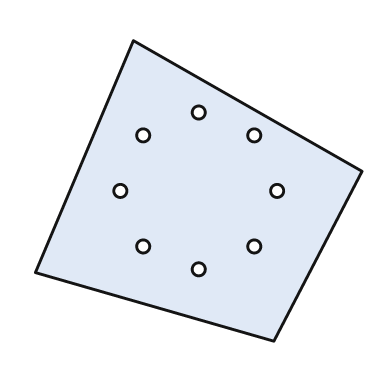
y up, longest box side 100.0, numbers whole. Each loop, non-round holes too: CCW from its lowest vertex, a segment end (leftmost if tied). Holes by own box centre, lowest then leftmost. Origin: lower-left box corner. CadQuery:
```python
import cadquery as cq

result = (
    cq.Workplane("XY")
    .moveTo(73.0, 0.0)
    .lineTo(100.0, 52.0)
    .lineTo(30.0, 92.0)
    .lineTo(0.0, 21.0)
    .close()
    .moveTo(50.0, 22.0)
    .circle(2.0)
    .moveTo(33.0, 29.0)
    .circle(2.0)
    .moveTo(67.0, 29.0)
    .circle(2.0)
    .moveTo(26.0, 46.0)
    .circle(2.0)
    .moveTo(74.0, 46.0)
    .circle(2.0)
    .moveTo(33.0, 63.0)
    .circle(2.0)
    .moveTo(67.0, 63.0)
    .circle(2.0)
    .moveTo(50.0, 70.0)
    .circle(2.0)
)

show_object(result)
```